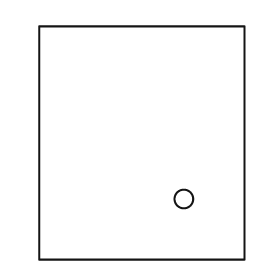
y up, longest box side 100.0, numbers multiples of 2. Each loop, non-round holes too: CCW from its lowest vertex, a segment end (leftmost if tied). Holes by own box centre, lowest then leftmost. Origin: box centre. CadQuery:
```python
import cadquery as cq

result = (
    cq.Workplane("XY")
    .moveTo(-44.0, -50.0)
    .lineTo(44.0, -50.0)
    .lineTo(44.0, 50.0)
    .lineTo(-44.0, 50.0)
    .close()
    .moveTo(18.0, -24.0)
    .circle(4.0)
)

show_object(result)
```